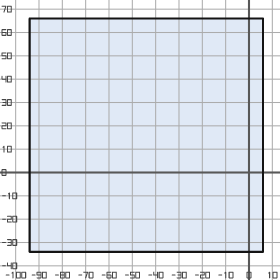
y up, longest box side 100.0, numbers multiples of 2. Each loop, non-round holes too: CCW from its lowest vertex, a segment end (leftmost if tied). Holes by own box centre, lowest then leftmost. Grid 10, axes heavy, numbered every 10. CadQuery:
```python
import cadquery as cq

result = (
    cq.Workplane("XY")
    .moveTo(-94.0, -34.0)
    .lineTo(6.0, -34.0)
    .lineTo(6.0, 66.0)
    .lineTo(-94.0, 66.0)
    .close()
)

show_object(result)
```